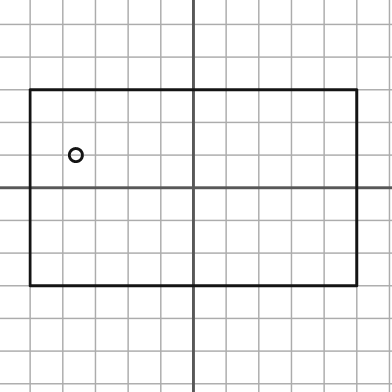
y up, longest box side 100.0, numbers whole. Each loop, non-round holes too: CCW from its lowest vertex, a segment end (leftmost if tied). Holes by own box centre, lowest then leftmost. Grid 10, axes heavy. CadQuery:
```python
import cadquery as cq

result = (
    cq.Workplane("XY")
    .moveTo(-50.0, -30.0)
    .lineTo(50.0, -30.0)
    .lineTo(50.0, 30.0)
    .lineTo(-50.0, 30.0)
    .close()
    .moveTo(-36.0, 10.0)
    .circle(2.0)
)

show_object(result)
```